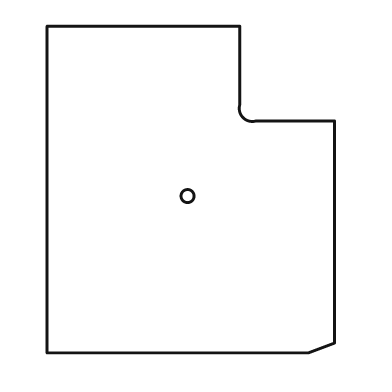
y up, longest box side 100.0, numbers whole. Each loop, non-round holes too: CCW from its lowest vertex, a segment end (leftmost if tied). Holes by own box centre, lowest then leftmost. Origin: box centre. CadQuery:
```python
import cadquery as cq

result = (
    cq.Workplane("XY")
    .moveTo(-44.0, -50.0)
    .lineTo(36.0, -50.0)
    .lineTo(44.0, -47.0)
    .lineTo(44.0, 21.0)
    .lineTo(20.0, 21.0)
    .threePointArc((16.0, 22.0), (15.0, 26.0))
    .lineTo(15.0, 50.0)
    .lineTo(-44.0, 50.0)
    .close()
    .moveTo(-1.0, -2.0)
    .circle(2.0)
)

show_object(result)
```